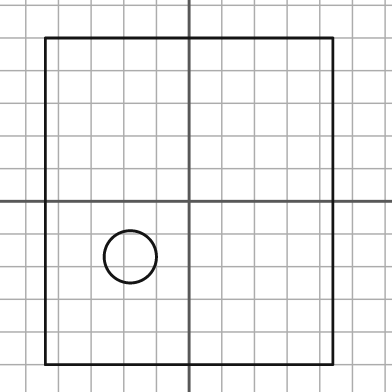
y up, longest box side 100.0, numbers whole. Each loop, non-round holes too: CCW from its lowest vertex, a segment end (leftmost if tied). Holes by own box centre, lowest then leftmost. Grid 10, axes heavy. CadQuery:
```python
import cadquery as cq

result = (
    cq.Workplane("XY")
    .moveTo(-44.0, -50.0)
    .lineTo(44.0, -50.0)
    .lineTo(44.0, 50.0)
    .lineTo(-44.0, 50.0)
    .close()
    .moveTo(-18.0, -17.0)
    .circle(8.0)
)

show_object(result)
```